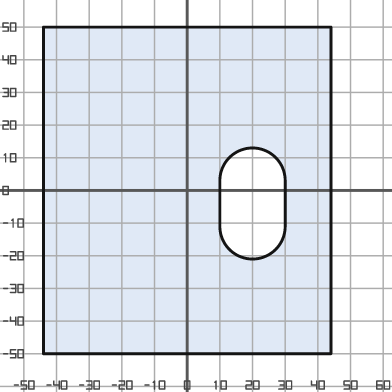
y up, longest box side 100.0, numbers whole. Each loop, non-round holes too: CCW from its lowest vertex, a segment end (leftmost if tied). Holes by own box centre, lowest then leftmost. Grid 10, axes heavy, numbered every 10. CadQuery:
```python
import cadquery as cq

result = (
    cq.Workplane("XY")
    .moveTo(-44.0, -50.0)
    .lineTo(44.0, -50.0)
    .lineTo(44.0, 50.0)
    .lineTo(-44.0, 50.0)
    .close()
    .moveTo(10.0, -11.0)
    .threePointArc((20.0, -21.0), (30.0, -11.0))
    .lineTo(30.0, 3.0)
    .threePointArc((20.0, 13.0), (10.0, 3.0))
    .close()
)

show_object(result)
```